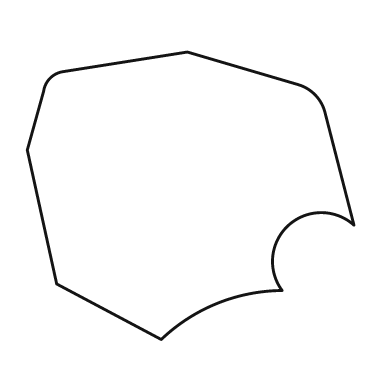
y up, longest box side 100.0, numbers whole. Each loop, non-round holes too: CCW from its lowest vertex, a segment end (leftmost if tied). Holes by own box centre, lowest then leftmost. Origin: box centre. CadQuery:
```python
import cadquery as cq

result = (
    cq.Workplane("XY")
    .moveTo(-9.0, -44.0)
    .threePointArc((8.0, -33.0), (28.0, -29.0))
    .threePointArc((30.0, -9.0), (50.0, -9.0))
    .lineTo(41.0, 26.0)
    .threePointArc((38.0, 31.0), (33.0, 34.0))
    .lineTo(-1.0, 44.0)
    .lineTo(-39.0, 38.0)
    .threePointArc((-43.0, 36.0), (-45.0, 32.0))
    .lineTo(-50.0, 14.0)
    .lineTo(-41.0, -27.0)
    .close()
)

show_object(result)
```